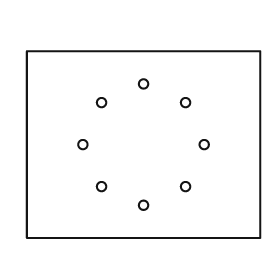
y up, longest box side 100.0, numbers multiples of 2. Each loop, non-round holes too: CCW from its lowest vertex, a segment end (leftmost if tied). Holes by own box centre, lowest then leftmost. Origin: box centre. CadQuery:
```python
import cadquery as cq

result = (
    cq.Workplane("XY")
    .moveTo(-50.0, -40.0)
    .lineTo(50.0, -40.0)
    .lineTo(50.0, 40.0)
    .lineTo(-50.0, 40.0)
    .close()
    .moveTo(0.0, -26.0)
    .circle(2.0)
    .moveTo(-18.0, -18.0)
    .circle(2.0)
    .moveTo(18.0, -18.0)
    .circle(2.0)
    .moveTo(-26.0, 0.0)
    .circle(2.0)
    .moveTo(26.0, 0.0)
    .circle(2.0)
    .moveTo(-18.0, 18.0)
    .circle(2.0)
    .moveTo(18.0, 18.0)
    .circle(2.0)
    .moveTo(0.0, 26.0)
    .circle(2.0)
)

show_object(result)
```